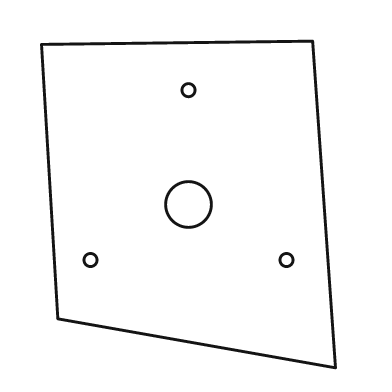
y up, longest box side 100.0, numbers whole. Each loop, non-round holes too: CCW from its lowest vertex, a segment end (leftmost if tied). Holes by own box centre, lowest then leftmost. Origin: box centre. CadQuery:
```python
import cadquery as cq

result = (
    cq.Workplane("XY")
    .moveTo(45.0, -50.0)
    .lineTo(38.0, 50.0)
    .lineTo(-45.0, 49.0)
    .lineTo(-40.0, -35.0)
    .close()
    .moveTo(-30.0, -17.0)
    .circle(2.0)
    .moveTo(30.0, -17.0)
    .circle(2.0)
    .moveTo(0.0, 0.0)
    .circle(7.0)
    .moveTo(0.0, 35.0)
    .circle(2.0)
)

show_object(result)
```